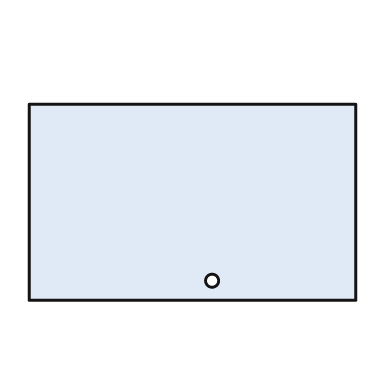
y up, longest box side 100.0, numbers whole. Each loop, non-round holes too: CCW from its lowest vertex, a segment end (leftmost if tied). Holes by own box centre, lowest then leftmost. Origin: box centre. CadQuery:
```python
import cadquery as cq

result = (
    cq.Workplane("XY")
    .moveTo(-50.0, -30.0)
    .lineTo(50.0, -30.0)
    .lineTo(50.0, 30.0)
    .lineTo(-50.0, 30.0)
    .close()
    .moveTo(6.0, -24.0)
    .circle(2.0)
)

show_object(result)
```